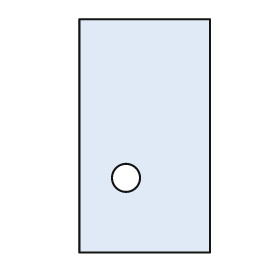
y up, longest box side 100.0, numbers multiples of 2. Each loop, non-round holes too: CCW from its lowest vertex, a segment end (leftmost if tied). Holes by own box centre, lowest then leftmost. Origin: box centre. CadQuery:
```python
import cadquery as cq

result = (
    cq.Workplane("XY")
    .moveTo(-28.0, -50.0)
    .lineTo(28.0, -50.0)
    .lineTo(28.0, 50.0)
    .lineTo(-28.0, 50.0)
    .close()
    .moveTo(-8.0, -18.0)
    .circle(6.0)
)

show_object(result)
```